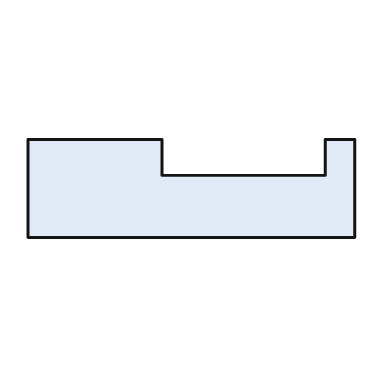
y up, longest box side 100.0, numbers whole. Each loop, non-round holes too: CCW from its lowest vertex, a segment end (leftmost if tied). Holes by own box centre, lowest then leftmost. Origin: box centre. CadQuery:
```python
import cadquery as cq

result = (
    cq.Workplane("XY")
    .moveTo(-50.0, -15.0)
    .lineTo(50.0, -15.0)
    .lineTo(50.0, 15.0)
    .lineTo(41.0, 15.0)
    .lineTo(41.0, 4.0)
    .lineTo(-9.0, 4.0)
    .lineTo(-9.0, 15.0)
    .lineTo(-50.0, 15.0)
    .close()
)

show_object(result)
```